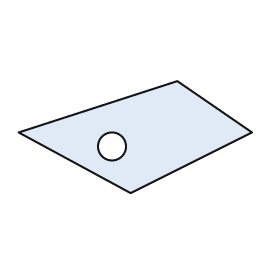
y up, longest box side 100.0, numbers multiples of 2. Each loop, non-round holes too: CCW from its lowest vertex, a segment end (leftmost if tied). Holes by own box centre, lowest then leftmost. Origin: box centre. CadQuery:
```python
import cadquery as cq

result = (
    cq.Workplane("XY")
    .moveTo(-2.0, -24.0)
    .lineTo(50.0, 2.0)
    .lineTo(18.0, 24.0)
    .lineTo(-50.0, 2.0)
    .close()
    .moveTo(-10.0, -4.0)
    .circle(6.0)
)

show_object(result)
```